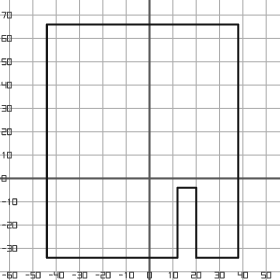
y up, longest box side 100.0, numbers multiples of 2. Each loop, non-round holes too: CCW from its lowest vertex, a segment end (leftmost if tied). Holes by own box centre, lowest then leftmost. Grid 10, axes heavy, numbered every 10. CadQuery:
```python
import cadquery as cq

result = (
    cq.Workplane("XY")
    .moveTo(-44.0, -34.0)
    .lineTo(12.0, -34.0)
    .lineTo(12.0, -4.0)
    .lineTo(20.0, -4.0)
    .lineTo(20.0, -34.0)
    .lineTo(38.0, -34.0)
    .lineTo(38.0, 66.0)
    .lineTo(-44.0, 66.0)
    .close()
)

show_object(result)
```